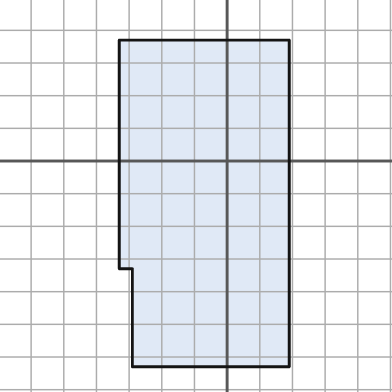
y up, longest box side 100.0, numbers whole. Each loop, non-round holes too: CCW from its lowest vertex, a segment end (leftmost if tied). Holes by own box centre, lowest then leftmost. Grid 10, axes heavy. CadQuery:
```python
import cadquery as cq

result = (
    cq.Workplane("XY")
    .moveTo(-29.0, -63.0)
    .lineTo(19.0, -63.0)
    .lineTo(19.0, 37.0)
    .lineTo(-33.0, 37.0)
    .lineTo(-33.0, -33.0)
    .lineTo(-29.0, -33.0)
    .close()
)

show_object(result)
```